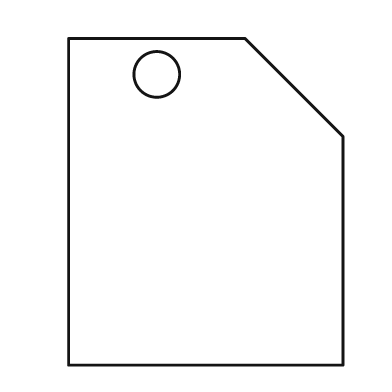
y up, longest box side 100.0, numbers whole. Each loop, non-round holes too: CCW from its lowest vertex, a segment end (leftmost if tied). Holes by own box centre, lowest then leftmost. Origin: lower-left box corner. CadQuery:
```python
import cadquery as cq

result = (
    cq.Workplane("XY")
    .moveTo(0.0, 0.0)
    .lineTo(84.0, 0.0)
    .lineTo(84.0, 70.0)
    .lineTo(54.0, 100.0)
    .lineTo(0.0, 100.0)
    .close()
    .moveTo(27.0, 89.0)
    .circle(7.0)
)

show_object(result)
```